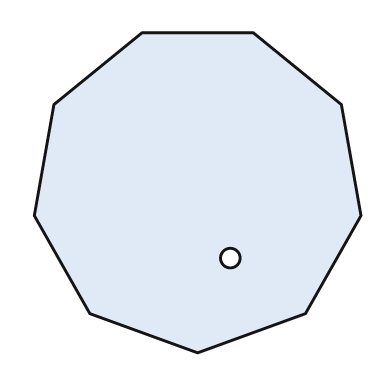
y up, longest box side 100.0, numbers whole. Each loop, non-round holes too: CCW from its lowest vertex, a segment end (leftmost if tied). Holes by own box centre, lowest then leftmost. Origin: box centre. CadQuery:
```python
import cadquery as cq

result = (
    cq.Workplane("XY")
    .moveTo(0.0, -49.0)
    .lineTo(33.0, -37.0)
    .lineTo(50.0, -7.0)
    .lineTo(44.0, 27.0)
    .lineTo(17.0, 49.0)
    .lineTo(-17.0, 49.0)
    .lineTo(-44.0, 27.0)
    .lineTo(-50.0, -7.0)
    .lineTo(-33.0, -37.0)
    .close()
    .moveTo(10.0, -20.0)
    .circle(3.0)
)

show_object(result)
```